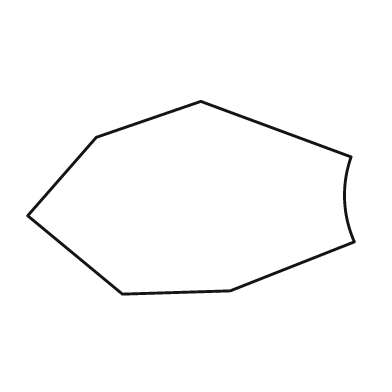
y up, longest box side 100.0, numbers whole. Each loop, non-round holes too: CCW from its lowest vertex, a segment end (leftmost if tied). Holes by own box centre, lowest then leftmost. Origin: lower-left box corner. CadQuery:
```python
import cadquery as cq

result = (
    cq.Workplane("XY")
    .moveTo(29.0, 0.0)
    .lineTo(62.0, 1.0)
    .lineTo(100.0, 16.0)
    .threePointArc((97.0, 29.0), (99.0, 42.0))
    .lineTo(53.0, 59.0)
    .lineTo(21.0, 48.0)
    .lineTo(0.0, 24.0)
    .close()
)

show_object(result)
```